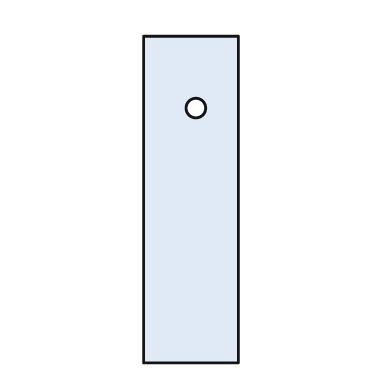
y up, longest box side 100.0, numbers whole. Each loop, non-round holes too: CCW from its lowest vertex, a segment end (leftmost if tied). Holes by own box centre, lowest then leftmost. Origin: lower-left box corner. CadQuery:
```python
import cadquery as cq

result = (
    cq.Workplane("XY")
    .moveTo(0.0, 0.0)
    .lineTo(29.0, 0.0)
    .lineTo(29.0, 100.0)
    .lineTo(0.0, 100.0)
    .close()
    .moveTo(16.0, 78.0)
    .circle(3.0)
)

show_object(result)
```